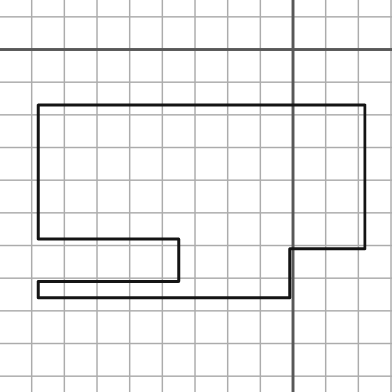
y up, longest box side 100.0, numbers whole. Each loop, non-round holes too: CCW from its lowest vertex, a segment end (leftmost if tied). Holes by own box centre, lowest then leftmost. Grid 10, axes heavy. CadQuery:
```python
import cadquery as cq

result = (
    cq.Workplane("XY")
    .moveTo(-78.0, -76.0)
    .lineTo(-1.0, -76.0)
    .lineTo(-1.0, -61.0)
    .lineTo(22.0, -61.0)
    .lineTo(22.0, -17.0)
    .lineTo(-78.0, -17.0)
    .lineTo(-78.0, -58.0)
    .lineTo(-35.0, -58.0)
    .lineTo(-35.0, -71.0)
    .lineTo(-78.0, -71.0)
    .close()
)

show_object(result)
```